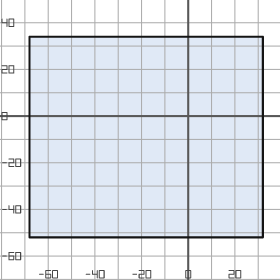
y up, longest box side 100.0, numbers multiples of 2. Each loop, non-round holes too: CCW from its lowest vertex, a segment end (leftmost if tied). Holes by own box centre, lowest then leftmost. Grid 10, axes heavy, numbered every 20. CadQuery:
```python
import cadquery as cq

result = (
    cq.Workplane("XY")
    .moveTo(-68.0, -52.0)
    .lineTo(32.0, -52.0)
    .lineTo(32.0, 34.0)
    .lineTo(-68.0, 34.0)
    .close()
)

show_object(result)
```